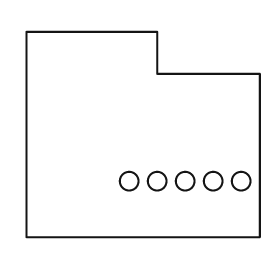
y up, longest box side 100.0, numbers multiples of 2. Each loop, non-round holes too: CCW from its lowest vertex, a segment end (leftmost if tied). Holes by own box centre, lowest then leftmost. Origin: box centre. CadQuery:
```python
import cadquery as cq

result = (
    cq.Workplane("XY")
    .moveTo(-50.0, -44.0)
    .lineTo(50.0, -44.0)
    .lineTo(50.0, 26.0)
    .lineTo(6.0, 26.0)
    .lineTo(6.0, 44.0)
    .lineTo(-50.0, 44.0)
    .close()
    .moveTo(-6.0, -20.0)
    .circle(4.0)
    .moveTo(6.0, -20.0)
    .circle(4.0)
    .moveTo(18.0, -20.0)
    .circle(4.0)
    .moveTo(30.0, -20.0)
    .circle(4.0)
    .moveTo(42.0, -20.0)
    .circle(4.0)
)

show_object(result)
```